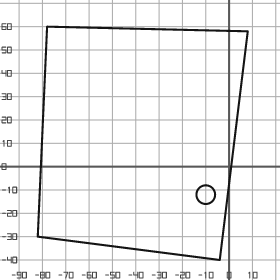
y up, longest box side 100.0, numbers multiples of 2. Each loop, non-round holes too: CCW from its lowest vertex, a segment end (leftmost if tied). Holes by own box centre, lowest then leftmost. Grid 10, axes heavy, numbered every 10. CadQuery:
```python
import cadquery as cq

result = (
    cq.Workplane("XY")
    .moveTo(-4.0, -40.0)
    .lineTo(8.0, 58.0)
    .lineTo(-78.0, 60.0)
    .lineTo(-82.0, -30.0)
    .close()
    .moveTo(-10.0, -12.0)
    .circle(4.0)
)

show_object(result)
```